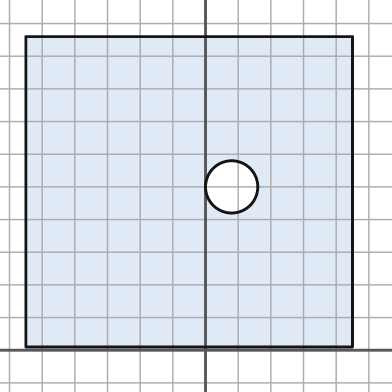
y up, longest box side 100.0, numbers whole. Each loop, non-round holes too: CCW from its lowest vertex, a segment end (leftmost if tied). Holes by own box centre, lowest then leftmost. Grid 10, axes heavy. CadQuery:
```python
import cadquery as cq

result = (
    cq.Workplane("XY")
    .moveTo(-55.0, 1.0)
    .lineTo(45.0, 1.0)
    .lineTo(45.0, 96.0)
    .lineTo(-55.0, 96.0)
    .close()
    .moveTo(8.0, 50.0)
    .circle(8.0)
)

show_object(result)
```